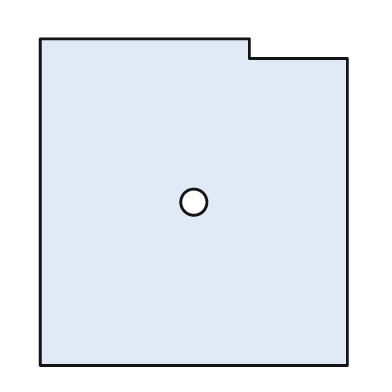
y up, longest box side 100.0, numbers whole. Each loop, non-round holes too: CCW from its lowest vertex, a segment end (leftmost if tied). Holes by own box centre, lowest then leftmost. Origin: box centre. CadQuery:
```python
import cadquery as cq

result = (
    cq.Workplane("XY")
    .moveTo(-47.0, -50.0)
    .lineTo(47.0, -50.0)
    .lineTo(47.0, 44.0)
    .lineTo(17.0, 44.0)
    .lineTo(17.0, 50.0)
    .lineTo(-47.0, 50.0)
    .close()
    .moveTo(0.0, 0.0)
    .circle(4.0)
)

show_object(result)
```